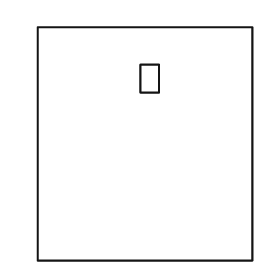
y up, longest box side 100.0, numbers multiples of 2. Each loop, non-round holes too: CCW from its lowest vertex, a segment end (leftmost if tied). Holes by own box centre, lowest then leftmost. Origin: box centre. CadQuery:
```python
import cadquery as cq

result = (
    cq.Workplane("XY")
    .moveTo(-46.0, -50.0)
    .lineTo(46.0, -50.0)
    .lineTo(46.0, 50.0)
    .lineTo(-46.0, 50.0)
    .close()
    .moveTo(-2.0, 22.0)
    .lineTo(6.0, 22.0)
    .lineTo(6.0, 34.0)
    .lineTo(-2.0, 34.0)
    .close()
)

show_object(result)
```